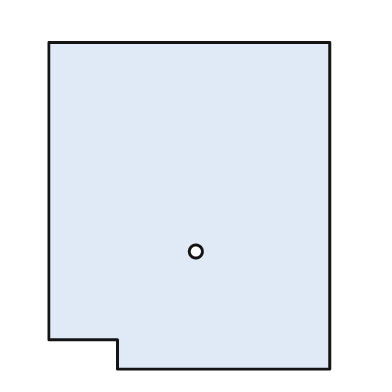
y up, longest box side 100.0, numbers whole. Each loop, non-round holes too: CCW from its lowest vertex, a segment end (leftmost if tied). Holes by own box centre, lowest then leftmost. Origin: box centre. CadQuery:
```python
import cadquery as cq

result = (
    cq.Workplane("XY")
    .moveTo(-22.0, -50.0)
    .lineTo(43.0, -50.0)
    .lineTo(43.0, 50.0)
    .lineTo(-43.0, 50.0)
    .lineTo(-43.0, -41.0)
    .lineTo(-22.0, -41.0)
    .close()
    .moveTo(2.0, -14.0)
    .circle(2.0)
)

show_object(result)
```